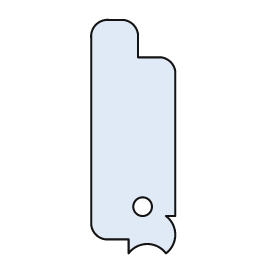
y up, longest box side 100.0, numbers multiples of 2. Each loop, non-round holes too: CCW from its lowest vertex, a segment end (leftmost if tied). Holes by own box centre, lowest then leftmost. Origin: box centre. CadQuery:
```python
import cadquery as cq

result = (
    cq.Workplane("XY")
    .moveTo(-2.0, -50.0)
    .threePointArc((6.0, -46.0), (14.0, -50.0))
    .threePointArc((18.0, -42.0), (14.0, -34.0))
    .lineTo(18.0, -34.0)
    .lineTo(18.0, 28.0)
    .threePointArc((16.0, 32.0), (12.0, 34.0))
    .lineTo(2.0, 34.0)
    .lineTo(2.0, 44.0)
    .threePointArc((0.0, 48.0), (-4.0, 50.0))
    .lineTo(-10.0, 50.0)
    .threePointArc((-16.0, 48.0), (-18.0, 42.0))
    .lineTo(-18.0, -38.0)
    .threePointArc((-16.0, -42.0), (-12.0, -44.0))
    .lineTo(-2.0, -44.0)
    .close()
    .moveTo(4.0, -30.0)
    .circle(4.0)
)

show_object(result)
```